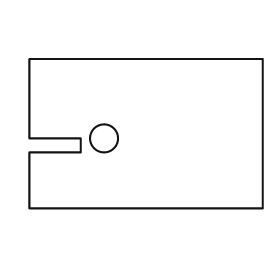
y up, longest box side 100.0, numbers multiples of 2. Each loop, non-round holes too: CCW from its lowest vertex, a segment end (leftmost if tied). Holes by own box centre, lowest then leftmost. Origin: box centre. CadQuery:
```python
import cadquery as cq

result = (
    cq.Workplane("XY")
    .moveTo(-50.0, -32.0)
    .lineTo(50.0, -32.0)
    .lineTo(50.0, 32.0)
    .lineTo(-50.0, 32.0)
    .lineTo(-50.0, -2.0)
    .lineTo(-28.0, -2.0)
    .lineTo(-28.0, -8.0)
    .lineTo(-50.0, -8.0)
    .close()
    .moveTo(-18.0, -2.0)
    .circle(6.0)
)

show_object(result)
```